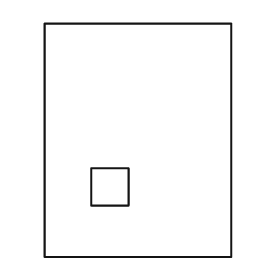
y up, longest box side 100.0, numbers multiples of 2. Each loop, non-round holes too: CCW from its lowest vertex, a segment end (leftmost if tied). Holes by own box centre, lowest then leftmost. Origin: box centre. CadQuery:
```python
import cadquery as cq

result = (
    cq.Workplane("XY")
    .moveTo(-40.0, -50.0)
    .lineTo(40.0, -50.0)
    .lineTo(40.0, 50.0)
    .lineTo(-40.0, 50.0)
    .close()
    .moveTo(-20.0, -28.0)
    .lineTo(-4.0, -28.0)
    .lineTo(-4.0, -12.0)
    .lineTo(-20.0, -12.0)
    .close()
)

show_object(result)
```